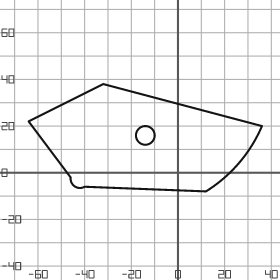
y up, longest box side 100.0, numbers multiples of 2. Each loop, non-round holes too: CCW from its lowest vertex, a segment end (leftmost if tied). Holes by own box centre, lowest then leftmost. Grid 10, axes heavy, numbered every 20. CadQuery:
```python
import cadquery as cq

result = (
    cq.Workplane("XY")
    .moveTo(12.0, -8.0)
    .threePointArc((26.0, 4.0), (36.0, 20.0))
    .lineTo(-32.0, 38.0)
    .lineTo(-64.0, 22.0)
    .lineTo(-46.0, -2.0)
    .threePointArc((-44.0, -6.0), (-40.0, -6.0))
    .close()
    .moveTo(-14.0, 16.0)
    .circle(4.0)
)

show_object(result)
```